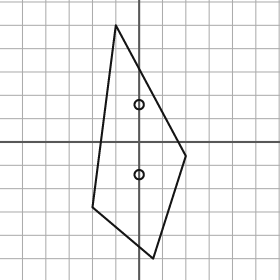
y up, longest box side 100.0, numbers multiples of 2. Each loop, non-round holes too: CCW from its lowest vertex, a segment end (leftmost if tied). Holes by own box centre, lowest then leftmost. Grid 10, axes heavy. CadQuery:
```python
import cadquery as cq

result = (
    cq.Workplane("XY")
    .moveTo(6.0, -50.0)
    .lineTo(20.0, -6.0)
    .lineTo(-10.0, 50.0)
    .lineTo(-20.0, -28.0)
    .close()
    .moveTo(0.0, -14.0)
    .circle(2.0)
    .moveTo(0.0, 16.0)
    .circle(2.0)
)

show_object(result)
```